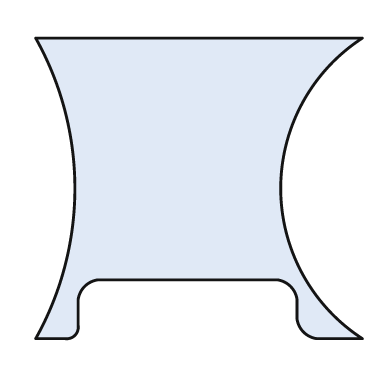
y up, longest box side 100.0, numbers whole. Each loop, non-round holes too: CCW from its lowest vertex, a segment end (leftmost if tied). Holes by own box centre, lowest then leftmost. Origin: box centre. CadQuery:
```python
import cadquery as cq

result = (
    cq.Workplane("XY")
    .moveTo(-50.0, -46.0)
    .lineTo(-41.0, -46.0)
    .threePointArc((-38.0, -45.0), (-37.0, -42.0))
    .lineTo(-37.0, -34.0)
    .threePointArc((-35.0, -30.0), (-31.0, -28.0))
    .lineTo(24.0, -28.0)
    .threePointArc((28.0, -30.0), (30.0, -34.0))
    .lineTo(30.0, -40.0)
    .threePointArc((32.0, -44.0), (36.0, -46.0))
    .lineTo(50.0, -46.0)
    .threePointArc((25.0, 0.0), (50.0, 46.0))
    .lineTo(-50.0, 46.0)
    .threePointArc((-38.0, 0.0), (-50.0, -46.0))
    .close()
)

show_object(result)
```